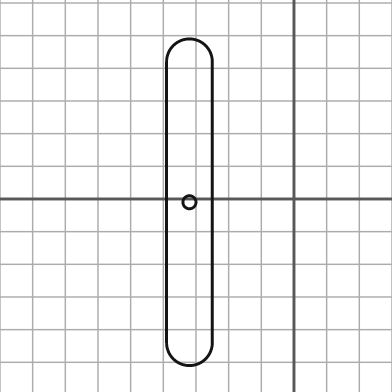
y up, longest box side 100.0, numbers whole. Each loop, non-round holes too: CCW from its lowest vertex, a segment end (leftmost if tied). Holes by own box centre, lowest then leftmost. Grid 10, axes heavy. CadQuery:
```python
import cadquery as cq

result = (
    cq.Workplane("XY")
    .moveTo(-39.0, -44.0)
    .threePointArc((-32.0, -51.0), (-25.0, -44.0))
    .lineTo(-25.0, 42.0)
    .threePointArc((-32.0, 49.0), (-39.0, 42.0))
    .close()
    .moveTo(-32.0, -1.0)
    .circle(2.0)
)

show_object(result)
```